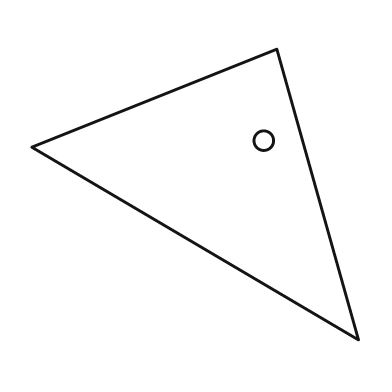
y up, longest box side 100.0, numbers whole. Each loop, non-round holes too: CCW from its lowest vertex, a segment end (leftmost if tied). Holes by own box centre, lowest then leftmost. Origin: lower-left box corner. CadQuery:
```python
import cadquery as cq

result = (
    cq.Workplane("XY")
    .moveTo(100.0, 0.0)
    .lineTo(75.0, 89.0)
    .lineTo(0.0, 59.0)
    .close()
    .moveTo(71.0, 61.0)
    .circle(3.0)
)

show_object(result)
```